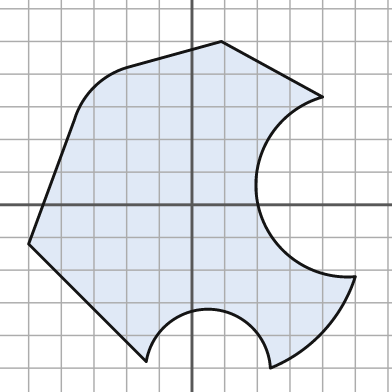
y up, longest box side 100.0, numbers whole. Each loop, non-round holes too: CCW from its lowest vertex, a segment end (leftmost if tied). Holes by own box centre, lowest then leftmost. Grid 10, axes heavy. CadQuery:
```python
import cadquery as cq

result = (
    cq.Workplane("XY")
    .moveTo(24.0, -50.0)
    .threePointArc((40.0, -39.0), (50.0, -22.0))
    .threePointArc((20.0, 1.0), (40.0, 33.0))
    .lineTo(9.0, 50.0)
    .lineTo(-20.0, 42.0)
    .threePointArc((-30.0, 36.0), (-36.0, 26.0))
    .lineTo(-50.0, -12.0)
    .lineTo(-14.0, -48.0)
    .threePointArc((6.0, -32.0), (24.0, -50.0))
    .close()
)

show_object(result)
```